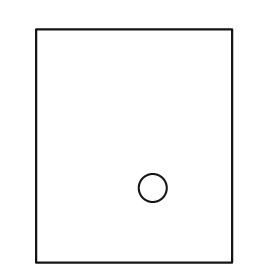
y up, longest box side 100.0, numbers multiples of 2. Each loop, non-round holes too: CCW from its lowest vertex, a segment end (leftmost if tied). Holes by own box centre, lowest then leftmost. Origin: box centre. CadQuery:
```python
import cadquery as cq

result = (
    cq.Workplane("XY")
    .moveTo(-42.0, -50.0)
    .lineTo(42.0, -50.0)
    .lineTo(42.0, 50.0)
    .lineTo(-42.0, 50.0)
    .close()
    .moveTo(8.0, -18.0)
    .circle(6.0)
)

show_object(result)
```